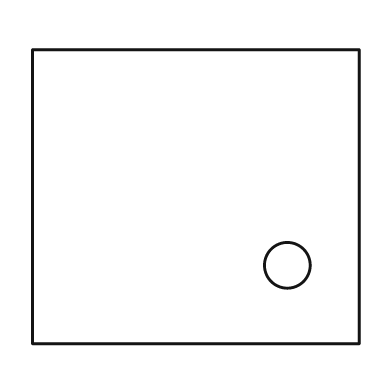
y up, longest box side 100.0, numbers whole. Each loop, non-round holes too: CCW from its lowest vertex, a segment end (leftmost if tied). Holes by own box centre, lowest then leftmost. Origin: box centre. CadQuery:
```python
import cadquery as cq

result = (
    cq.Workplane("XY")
    .moveTo(-50.0, -45.0)
    .lineTo(50.0, -45.0)
    .lineTo(50.0, 45.0)
    .lineTo(-50.0, 45.0)
    .close()
    .moveTo(28.0, -21.0)
    .circle(7.0)
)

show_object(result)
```